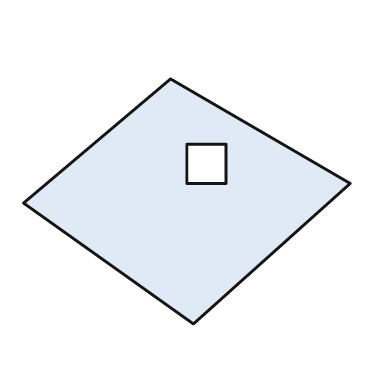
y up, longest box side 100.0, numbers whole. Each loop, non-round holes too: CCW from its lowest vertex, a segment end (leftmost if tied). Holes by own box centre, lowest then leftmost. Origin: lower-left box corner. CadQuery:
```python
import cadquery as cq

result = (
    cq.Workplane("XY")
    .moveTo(52.0, 0.0)
    .lineTo(100.0, 43.0)
    .lineTo(45.0, 75.0)
    .lineTo(0.0, 37.0)
    .close()
    .moveTo(50.0, 43.0)
    .lineTo(62.0, 43.0)
    .lineTo(62.0, 55.0)
    .lineTo(50.0, 55.0)
    .close()
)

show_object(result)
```